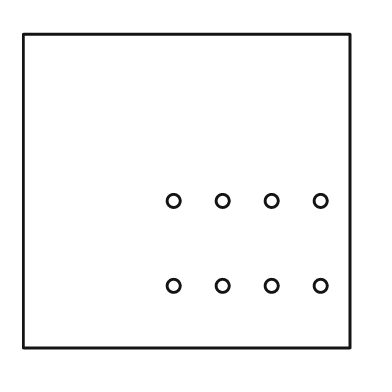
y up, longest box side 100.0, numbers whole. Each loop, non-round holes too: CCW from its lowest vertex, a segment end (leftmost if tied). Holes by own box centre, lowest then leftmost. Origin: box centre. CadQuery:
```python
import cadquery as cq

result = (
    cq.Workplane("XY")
    .moveTo(-50.0, -48.0)
    .lineTo(50.0, -48.0)
    .lineTo(50.0, 48.0)
    .lineTo(-50.0, 48.0)
    .close()
    .moveTo(-4.0, -29.0)
    .circle(2.0)
    .moveTo(11.0, -29.0)
    .circle(2.0)
    .moveTo(26.0, -29.0)
    .circle(2.0)
    .moveTo(41.0, -29.0)
    .circle(2.0)
    .moveTo(-4.0, -3.0)
    .circle(2.0)
    .moveTo(11.0, -3.0)
    .circle(2.0)
    .moveTo(26.0, -3.0)
    .circle(2.0)
    .moveTo(41.0, -3.0)
    .circle(2.0)
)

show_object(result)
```